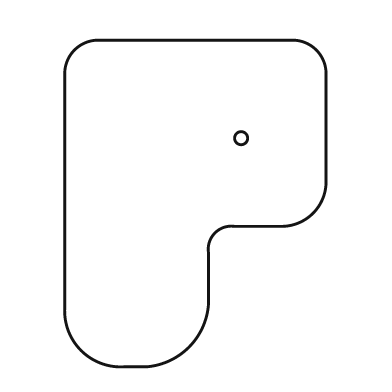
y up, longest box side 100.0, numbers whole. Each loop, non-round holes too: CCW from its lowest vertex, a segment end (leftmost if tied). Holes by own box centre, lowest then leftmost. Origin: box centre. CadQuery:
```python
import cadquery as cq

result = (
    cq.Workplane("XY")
    .moveTo(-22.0, -50.0)
    .lineTo(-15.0, -50.0)
    .threePointArc((-2.0, -44.0), (4.0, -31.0))
    .lineTo(4.0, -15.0)
    .threePointArc((6.0, -9.0), (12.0, -7.0))
    .lineTo(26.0, -7.0)
    .threePointArc((36.0, -3.0), (40.0, 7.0))
    .lineTo(40.0, 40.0)
    .threePointArc((37.0, 47.0), (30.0, 50.0))
    .lineTo(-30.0, 50.0)
    .threePointArc((-37.0, 47.0), (-40.0, 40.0))
    .lineTo(-40.0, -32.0)
    .threePointArc((-35.0, -45.0), (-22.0, -50.0))
    .close()
    .moveTo(14.0, 20.0)
    .circle(2.0)
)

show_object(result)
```